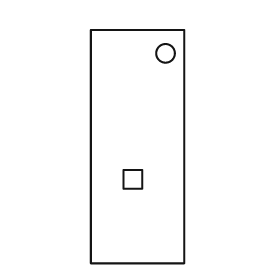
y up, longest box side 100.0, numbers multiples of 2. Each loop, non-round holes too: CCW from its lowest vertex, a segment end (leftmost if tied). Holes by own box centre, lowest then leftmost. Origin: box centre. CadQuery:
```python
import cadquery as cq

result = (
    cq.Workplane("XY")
    .moveTo(-20.0, -50.0)
    .lineTo(20.0, -50.0)
    .lineTo(20.0, 50.0)
    .lineTo(-20.0, 50.0)
    .close()
    .moveTo(-6.0, -18.0)
    .lineTo(2.0, -18.0)
    .lineTo(2.0, -10.0)
    .lineTo(-6.0, -10.0)
    .close()
    .moveTo(12.0, 40.0)
    .circle(4.0)
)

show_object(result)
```